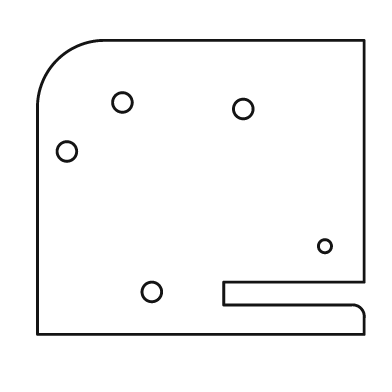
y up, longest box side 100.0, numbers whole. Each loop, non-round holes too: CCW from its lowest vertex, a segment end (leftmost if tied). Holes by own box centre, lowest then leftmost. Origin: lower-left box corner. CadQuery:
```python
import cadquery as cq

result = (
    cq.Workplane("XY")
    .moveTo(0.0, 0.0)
    .lineTo(100.0, 0.0)
    .lineTo(100.0, 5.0)
    .threePointArc((99.0, 8.0), (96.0, 9.0))
    .lineTo(57.0, 9.0)
    .lineTo(57.0, 16.0)
    .lineTo(100.0, 16.0)
    .lineTo(100.0, 90.0)
    .lineTo(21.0, 90.0)
    .threePointArc((6.0, 84.0), (0.0, 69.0))
    .close()
    .moveTo(35.0, 13.0)
    .circle(3.0)
    .moveTo(88.0, 27.0)
    .circle(2.0)
    .moveTo(9.0, 56.0)
    .circle(3.0)
    .moveTo(63.0, 69.0)
    .circle(3.0)
    .moveTo(26.0, 71.0)
    .circle(3.0)
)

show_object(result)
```